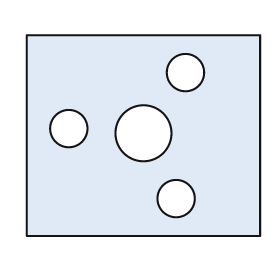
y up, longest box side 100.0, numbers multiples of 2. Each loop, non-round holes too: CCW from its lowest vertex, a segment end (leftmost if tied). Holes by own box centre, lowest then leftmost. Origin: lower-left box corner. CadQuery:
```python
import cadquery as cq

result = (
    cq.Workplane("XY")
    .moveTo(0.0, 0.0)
    .lineTo(100.0, 0.0)
    .lineTo(100.0, 86.0)
    .lineTo(0.0, 86.0)
    .close()
    .moveTo(64.0, 16.0)
    .circle(8.0)
    .moveTo(50.0, 44.0)
    .circle(12.0)
    .moveTo(18.0, 46.0)
    .circle(8.0)
    .moveTo(68.0, 70.0)
    .circle(8.0)
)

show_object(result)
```